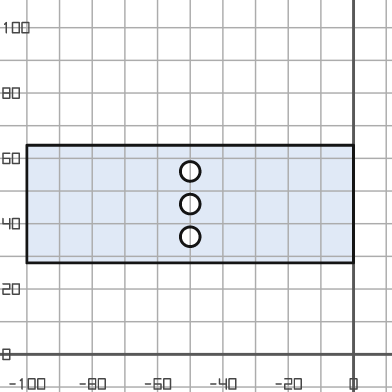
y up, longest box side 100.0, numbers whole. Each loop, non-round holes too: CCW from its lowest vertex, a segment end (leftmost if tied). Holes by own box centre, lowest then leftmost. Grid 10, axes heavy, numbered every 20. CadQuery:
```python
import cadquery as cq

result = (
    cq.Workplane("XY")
    .moveTo(-100.0, 28.0)
    .lineTo(0.0, 28.0)
    .lineTo(0.0, 64.0)
    .lineTo(-100.0, 64.0)
    .close()
    .moveTo(-50.0, 36.0)
    .circle(3.0)
    .moveTo(-50.0, 46.0)
    .circle(3.0)
    .moveTo(-50.0, 56.0)
    .circle(3.0)
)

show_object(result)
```